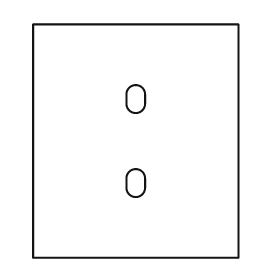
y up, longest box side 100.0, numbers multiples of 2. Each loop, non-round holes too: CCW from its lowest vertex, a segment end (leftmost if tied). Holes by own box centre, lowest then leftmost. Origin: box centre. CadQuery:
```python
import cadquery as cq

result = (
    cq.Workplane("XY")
    .moveTo(-44.0, -50.0)
    .lineTo(44.0, -50.0)
    .lineTo(44.0, 50.0)
    .lineTo(-44.0, 50.0)
    .close()
    .moveTo(-4.0, -20.0)
    .threePointArc((0.0, -24.0), (4.0, -20.0))
    .lineTo(4.0, -16.0)
    .threePointArc((0.0, -12.0), (-4.0, -16.0))
    .close()
    .moveTo(-4.0, 16.0)
    .threePointArc((0.0, 12.0), (4.0, 16.0))
    .lineTo(4.0, 20.0)
    .threePointArc((0.0, 24.0), (-4.0, 20.0))
    .close()
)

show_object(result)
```